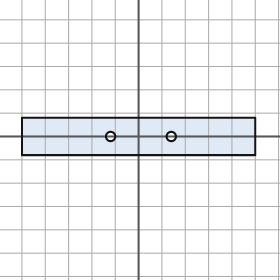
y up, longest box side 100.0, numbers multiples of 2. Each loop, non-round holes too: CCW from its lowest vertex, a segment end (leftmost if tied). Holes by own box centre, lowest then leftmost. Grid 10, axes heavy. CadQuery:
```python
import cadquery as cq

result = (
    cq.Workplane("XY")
    .moveTo(-50.0, -8.0)
    .lineTo(50.0, -8.0)
    .lineTo(50.0, 8.0)
    .lineTo(-50.0, 8.0)
    .close()
    .moveTo(-12.0, 0.0)
    .circle(2.0)
    .moveTo(14.0, 0.0)
    .circle(2.0)
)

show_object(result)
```